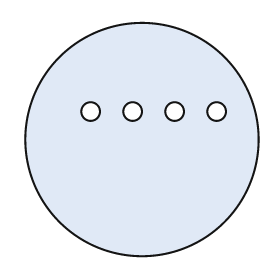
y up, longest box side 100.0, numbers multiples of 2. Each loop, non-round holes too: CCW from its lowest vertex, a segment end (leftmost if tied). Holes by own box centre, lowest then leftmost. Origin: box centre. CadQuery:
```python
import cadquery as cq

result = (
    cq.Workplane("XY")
    .moveTo(0.0, 0.0)
    .circle(50.0)
    .moveTo(-22.0, 12.0)
    .circle(4.0)
    .moveTo(-4.0, 12.0)
    .circle(4.0)
    .moveTo(14.0, 12.0)
    .circle(4.0)
    .moveTo(32.0, 12.0)
    .circle(4.0)
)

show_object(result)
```